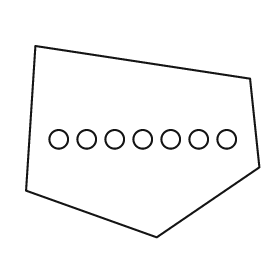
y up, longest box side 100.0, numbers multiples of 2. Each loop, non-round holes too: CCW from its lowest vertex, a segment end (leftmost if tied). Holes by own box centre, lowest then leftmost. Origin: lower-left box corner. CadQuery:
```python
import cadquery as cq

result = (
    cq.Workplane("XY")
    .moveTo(56.0, 0.0)
    .lineTo(100.0, 30.0)
    .lineTo(96.0, 68.0)
    .lineTo(4.0, 82.0)
    .lineTo(0.0, 20.0)
    .close()
    .moveTo(14.0, 42.0)
    .circle(4.0)
    .moveTo(26.0, 42.0)
    .circle(4.0)
    .moveTo(38.0, 42.0)
    .circle(4.0)
    .moveTo(50.0, 42.0)
    .circle(4.0)
    .moveTo(62.0, 42.0)
    .circle(4.0)
    .moveTo(74.0, 42.0)
    .circle(4.0)
    .moveTo(86.0, 42.0)
    .circle(4.0)
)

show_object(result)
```